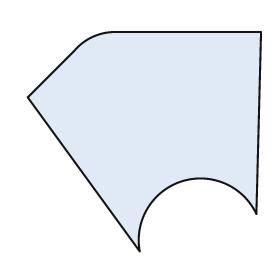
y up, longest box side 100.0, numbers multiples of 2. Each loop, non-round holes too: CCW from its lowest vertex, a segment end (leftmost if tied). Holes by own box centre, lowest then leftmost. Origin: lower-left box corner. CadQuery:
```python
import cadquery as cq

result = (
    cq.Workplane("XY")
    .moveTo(48.0, 0.0)
    .threePointArc((66.0, 30.0), (98.0, 16.0))
    .lineTo(100.0, 94.0)
    .lineTo(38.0, 94.0)
    .threePointArc((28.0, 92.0), (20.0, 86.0))
    .lineTo(0.0, 66.0)
    .close()
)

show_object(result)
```